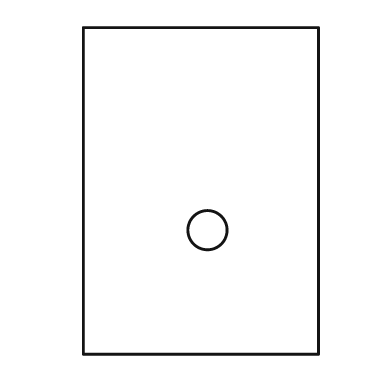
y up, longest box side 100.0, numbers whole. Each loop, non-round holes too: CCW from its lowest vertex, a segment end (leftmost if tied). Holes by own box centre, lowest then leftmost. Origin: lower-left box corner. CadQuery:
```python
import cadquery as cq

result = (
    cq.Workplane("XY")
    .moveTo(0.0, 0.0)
    .lineTo(72.0, 0.0)
    .lineTo(72.0, 100.0)
    .lineTo(0.0, 100.0)
    .close()
    .moveTo(38.0, 38.0)
    .circle(6.0)
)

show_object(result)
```